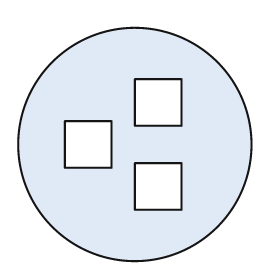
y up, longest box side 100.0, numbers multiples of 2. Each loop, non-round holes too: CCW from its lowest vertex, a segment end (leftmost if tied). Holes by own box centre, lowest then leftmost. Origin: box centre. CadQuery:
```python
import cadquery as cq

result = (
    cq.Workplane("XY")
    .moveTo(0.0, 0.0)
    .circle(50.0)
    .moveTo(0.0, -28.0)
    .lineTo(20.0, -28.0)
    .lineTo(20.0, -8.0)
    .lineTo(0.0, -8.0)
    .close()
    .moveTo(-30.0, -10.0)
    .lineTo(-10.0, -10.0)
    .lineTo(-10.0, 10.0)
    .lineTo(-30.0, 10.0)
    .close()
    .moveTo(0.0, 8.0)
    .lineTo(20.0, 8.0)
    .lineTo(20.0, 28.0)
    .lineTo(0.0, 28.0)
    .close()
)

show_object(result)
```